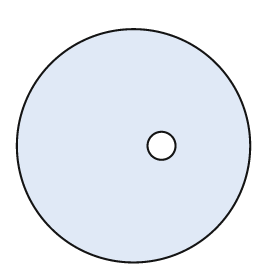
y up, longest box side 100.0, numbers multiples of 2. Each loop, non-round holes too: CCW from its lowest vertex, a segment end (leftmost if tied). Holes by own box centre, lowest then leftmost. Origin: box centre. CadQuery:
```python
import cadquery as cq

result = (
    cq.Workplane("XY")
    .moveTo(0.0, 0.0)
    .circle(50.0)
    .moveTo(12.0, 0.0)
    .circle(6.0)
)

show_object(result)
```